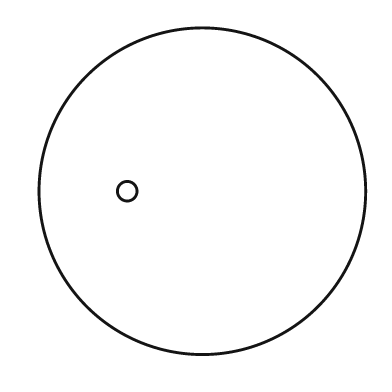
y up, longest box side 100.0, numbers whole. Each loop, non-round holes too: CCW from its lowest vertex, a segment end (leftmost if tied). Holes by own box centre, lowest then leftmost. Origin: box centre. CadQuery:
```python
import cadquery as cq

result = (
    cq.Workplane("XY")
    .moveTo(0.0, 0.0)
    .circle(50.0)
    .moveTo(-23.0, 0.0)
    .circle(3.0)
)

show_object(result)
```